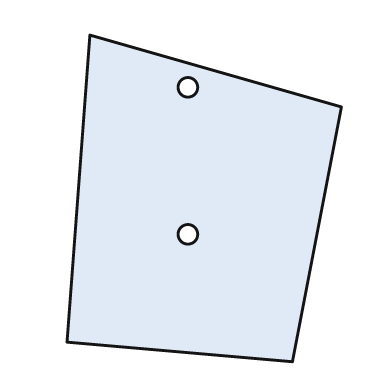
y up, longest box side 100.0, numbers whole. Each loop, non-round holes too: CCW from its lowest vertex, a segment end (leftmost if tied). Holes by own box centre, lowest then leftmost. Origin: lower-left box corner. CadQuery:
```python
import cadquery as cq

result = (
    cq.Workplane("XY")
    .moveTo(69.0, 0.0)
    .lineTo(84.0, 78.0)
    .lineTo(7.0, 100.0)
    .lineTo(0.0, 6.0)
    .close()
    .moveTo(37.0, 39.0)
    .circle(3.0)
    .moveTo(37.0, 84.0)
    .circle(3.0)
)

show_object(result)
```